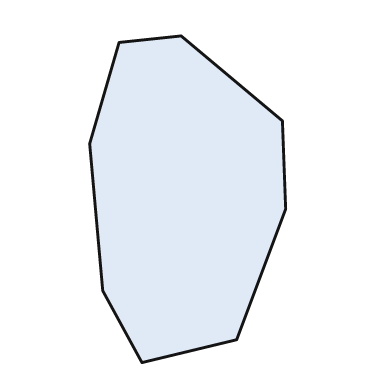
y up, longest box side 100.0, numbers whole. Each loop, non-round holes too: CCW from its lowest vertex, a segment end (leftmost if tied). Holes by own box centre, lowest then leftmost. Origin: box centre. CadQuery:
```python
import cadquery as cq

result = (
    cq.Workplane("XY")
    .moveTo(-14.0, -50.0)
    .lineTo(15.0, -43.0)
    .lineTo(30.0, -3.0)
    .lineTo(29.0, 24.0)
    .lineTo(-2.0, 50.0)
    .lineTo(-21.0, 48.0)
    .lineTo(-30.0, 17.0)
    .lineTo(-26.0, -28.0)
    .close()
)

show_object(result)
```